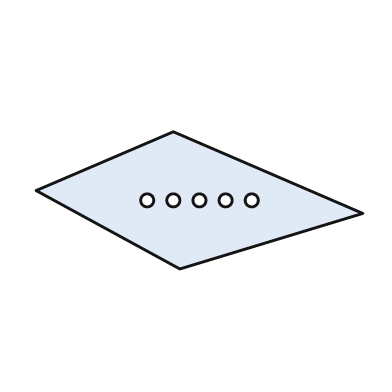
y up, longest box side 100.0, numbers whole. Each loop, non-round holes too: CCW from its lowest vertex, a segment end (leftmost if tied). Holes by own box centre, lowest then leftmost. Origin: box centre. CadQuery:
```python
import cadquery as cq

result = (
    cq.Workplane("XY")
    .moveTo(-6.0, -21.0)
    .lineTo(50.0, -4.0)
    .lineTo(-8.0, 21.0)
    .lineTo(-50.0, 3.0)
    .close()
    .moveTo(-16.0, 0.0)
    .circle(2.0)
    .moveTo(-8.0, 0.0)
    .circle(2.0)
    .moveTo(0.0, 0.0)
    .circle(2.0)
    .moveTo(8.0, 0.0)
    .circle(2.0)
    .moveTo(16.0, 0.0)
    .circle(2.0)
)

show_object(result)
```